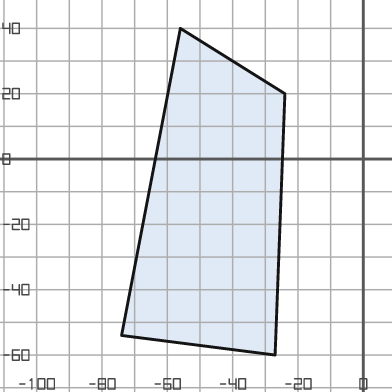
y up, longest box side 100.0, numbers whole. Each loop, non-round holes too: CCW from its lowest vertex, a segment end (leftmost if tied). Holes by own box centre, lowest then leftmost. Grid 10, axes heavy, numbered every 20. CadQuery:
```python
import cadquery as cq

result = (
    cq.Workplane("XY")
    .moveTo(-27.0, -60.0)
    .lineTo(-24.0, 20.0)
    .lineTo(-56.0, 40.0)
    .lineTo(-74.0, -54.0)
    .close()
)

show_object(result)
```